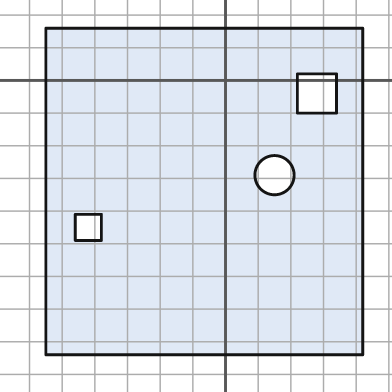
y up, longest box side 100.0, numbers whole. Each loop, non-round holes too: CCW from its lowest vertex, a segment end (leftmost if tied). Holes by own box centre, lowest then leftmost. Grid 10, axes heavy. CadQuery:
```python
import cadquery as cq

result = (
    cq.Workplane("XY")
    .moveTo(-55.0, -84.0)
    .lineTo(42.0, -84.0)
    .lineTo(42.0, 16.0)
    .lineTo(-55.0, 16.0)
    .close()
    .moveTo(-46.0, -49.0)
    .lineTo(-38.0, -49.0)
    .lineTo(-38.0, -41.0)
    .lineTo(-46.0, -41.0)
    .close()
    .moveTo(15.0, -29.0)
    .circle(6.0)
    .moveTo(22.0, -10.0)
    .lineTo(34.0, -10.0)
    .lineTo(34.0, 2.0)
    .lineTo(22.0, 2.0)
    .close()
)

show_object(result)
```